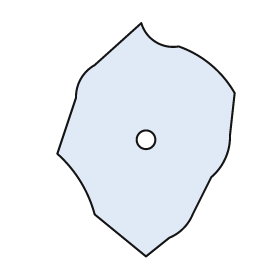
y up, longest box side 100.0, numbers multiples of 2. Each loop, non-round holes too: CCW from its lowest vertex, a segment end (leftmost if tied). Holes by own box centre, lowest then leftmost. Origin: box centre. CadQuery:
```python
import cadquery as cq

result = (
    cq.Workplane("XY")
    .moveTo(0.0, -50.0)
    .lineTo(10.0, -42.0)
    .threePointArc((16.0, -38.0), (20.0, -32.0))
    .lineTo(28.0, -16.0)
    .threePointArc((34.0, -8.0), (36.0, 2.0))
    .lineTo(38.0, 20.0)
    .threePointArc((28.0, 32.0), (14.0, 40.0))
    .threePointArc((4.0, 42.0), (-2.0, 50.0))
    .lineTo(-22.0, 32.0)
    .threePointArc((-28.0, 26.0), (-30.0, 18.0))
    .lineTo(-38.0, -6.0)
    .threePointArc((-28.0, -18.0), (-22.0, -32.0))
    .close()
    .moveTo(0.0, 0.0)
    .circle(4.0)
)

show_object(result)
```